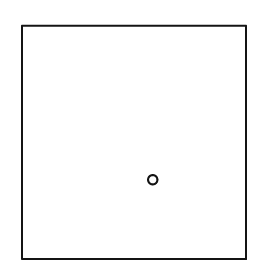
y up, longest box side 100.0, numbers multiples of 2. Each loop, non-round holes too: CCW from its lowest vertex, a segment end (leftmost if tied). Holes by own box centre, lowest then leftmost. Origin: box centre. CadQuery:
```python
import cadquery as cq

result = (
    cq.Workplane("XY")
    .moveTo(-48.0, -50.0)
    .lineTo(48.0, -50.0)
    .lineTo(48.0, 50.0)
    .lineTo(-48.0, 50.0)
    .close()
    .moveTo(8.0, -16.0)
    .circle(2.0)
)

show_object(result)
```